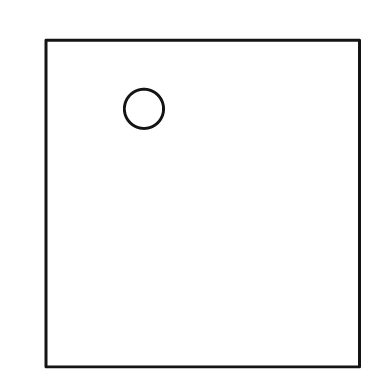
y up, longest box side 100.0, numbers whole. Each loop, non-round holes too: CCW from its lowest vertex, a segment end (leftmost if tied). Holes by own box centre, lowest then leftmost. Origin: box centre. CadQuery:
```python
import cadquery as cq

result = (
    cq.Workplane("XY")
    .moveTo(-48.0, -50.0)
    .lineTo(48.0, -50.0)
    .lineTo(48.0, 50.0)
    .lineTo(-48.0, 50.0)
    .close()
    .moveTo(-18.0, 29.0)
    .circle(6.0)
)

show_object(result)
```